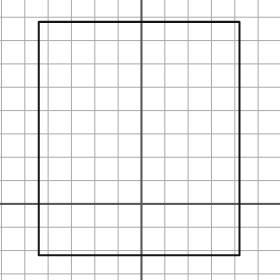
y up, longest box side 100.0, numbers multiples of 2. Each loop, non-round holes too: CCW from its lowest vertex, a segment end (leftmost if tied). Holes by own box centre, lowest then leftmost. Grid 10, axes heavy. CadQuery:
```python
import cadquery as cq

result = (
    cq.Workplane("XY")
    .moveTo(-44.0, -22.0)
    .lineTo(42.0, -22.0)
    .lineTo(42.0, 78.0)
    .lineTo(-44.0, 78.0)
    .close()
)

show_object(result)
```